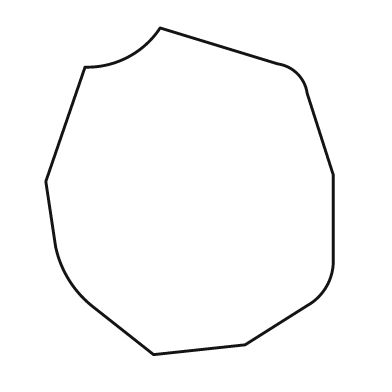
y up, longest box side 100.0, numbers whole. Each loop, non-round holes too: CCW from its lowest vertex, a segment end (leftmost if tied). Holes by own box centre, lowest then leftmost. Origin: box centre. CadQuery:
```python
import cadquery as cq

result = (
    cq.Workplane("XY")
    .moveTo(-11.0, -50.0)
    .lineTo(17.0, -47.0)
    .lineTo(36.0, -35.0)
    .threePointArc((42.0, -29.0), (44.0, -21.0))
    .lineTo(44.0, 5.0)
    .lineTo(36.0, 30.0)
    .threePointArc((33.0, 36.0), (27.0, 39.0))
    .lineTo(-9.0, 50.0)
    .threePointArc((-19.0, 41.0), (-32.0, 38.0))
    .lineTo(-44.0, 3.0)
    .lineTo(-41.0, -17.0)
    .threePointArc((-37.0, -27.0), (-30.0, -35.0))
    .close()
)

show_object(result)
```